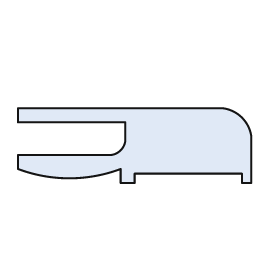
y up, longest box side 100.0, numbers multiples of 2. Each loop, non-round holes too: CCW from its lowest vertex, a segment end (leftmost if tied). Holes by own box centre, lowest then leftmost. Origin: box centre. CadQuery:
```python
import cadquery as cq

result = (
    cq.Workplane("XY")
    .moveTo(-6.0, -16.0)
    .lineTo(0.0, -16.0)
    .lineTo(0.0, -12.0)
    .lineTo(46.0, -12.0)
    .lineTo(46.0, -16.0)
    .lineTo(50.0, -16.0)
    .lineTo(50.0, 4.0)
    .threePointArc((46.0, 12.0), (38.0, 16.0))
    .lineTo(-50.0, 16.0)
    .lineTo(-50.0, 10.0)
    .lineTo(-4.0, 10.0)
    .lineTo(-4.0, 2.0)
    .threePointArc((-6.0, -2.0), (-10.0, -4.0))
    .lineTo(-50.0, -4.0)
    .lineTo(-50.0, -10.0)
    .threePointArc((-28.0, -14.0), (-6.0, -10.0))
    .close()
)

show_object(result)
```